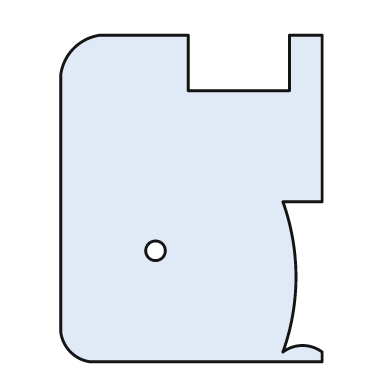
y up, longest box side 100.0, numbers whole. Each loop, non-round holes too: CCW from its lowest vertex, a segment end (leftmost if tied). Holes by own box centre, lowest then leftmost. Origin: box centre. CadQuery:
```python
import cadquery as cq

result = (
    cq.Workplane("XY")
    .moveTo(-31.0, -50.0)
    .lineTo(40.0, -50.0)
    .lineTo(40.0, -47.0)
    .threePointArc((34.0, -45.0), (28.0, -47.0))
    .threePointArc((32.0, -24.0), (28.0, -1.0))
    .lineTo(40.0, -1.0)
    .lineTo(40.0, 50.0)
    .lineTo(30.0, 50.0)
    .lineTo(30.0, 33.0)
    .lineTo(-1.0, 33.0)
    .lineTo(-1.0, 50.0)
    .lineTo(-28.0, 50.0)
    .threePointArc((-36.0, 46.0), (-40.0, 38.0))
    .lineTo(-40.0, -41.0)
    .threePointArc((-37.0, -47.0), (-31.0, -50.0))
    .close()
    .moveTo(-11.0, -16.0)
    .circle(3.0)
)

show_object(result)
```